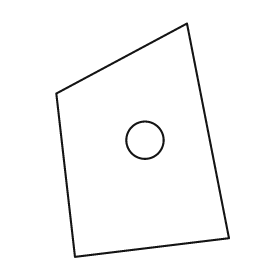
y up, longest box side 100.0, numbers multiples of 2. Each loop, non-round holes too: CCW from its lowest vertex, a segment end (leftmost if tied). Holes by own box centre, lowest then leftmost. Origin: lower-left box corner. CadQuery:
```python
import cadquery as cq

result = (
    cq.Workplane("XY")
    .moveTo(8.0, 0.0)
    .lineTo(74.0, 8.0)
    .lineTo(56.0, 100.0)
    .lineTo(0.0, 70.0)
    .close()
    .moveTo(38.0, 50.0)
    .circle(8.0)
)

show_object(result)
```